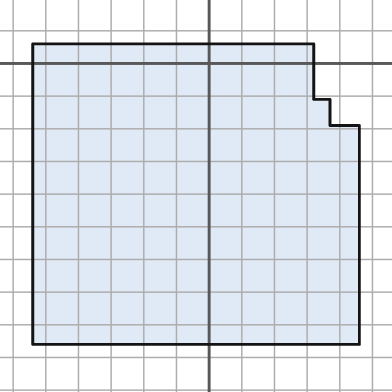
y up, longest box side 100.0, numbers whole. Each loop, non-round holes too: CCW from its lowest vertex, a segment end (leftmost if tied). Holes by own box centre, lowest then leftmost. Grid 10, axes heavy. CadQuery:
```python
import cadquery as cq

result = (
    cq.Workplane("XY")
    .moveTo(-54.0, -86.0)
    .lineTo(46.0, -86.0)
    .lineTo(46.0, -19.0)
    .lineTo(37.0, -19.0)
    .lineTo(37.0, -11.0)
    .lineTo(32.0, -11.0)
    .lineTo(32.0, 6.0)
    .lineTo(-54.0, 6.0)
    .close()
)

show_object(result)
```